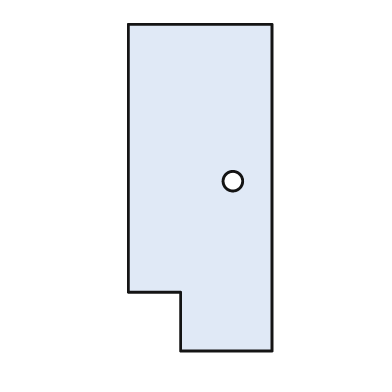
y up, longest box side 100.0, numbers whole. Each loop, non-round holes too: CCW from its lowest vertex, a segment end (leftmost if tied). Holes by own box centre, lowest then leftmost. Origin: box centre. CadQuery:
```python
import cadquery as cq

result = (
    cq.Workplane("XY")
    .moveTo(-6.0, -50.0)
    .lineTo(22.0, -50.0)
    .lineTo(22.0, 50.0)
    .lineTo(-22.0, 50.0)
    .lineTo(-22.0, -32.0)
    .lineTo(-6.0, -32.0)
    .close()
    .moveTo(10.0, 2.0)
    .circle(3.0)
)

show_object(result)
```